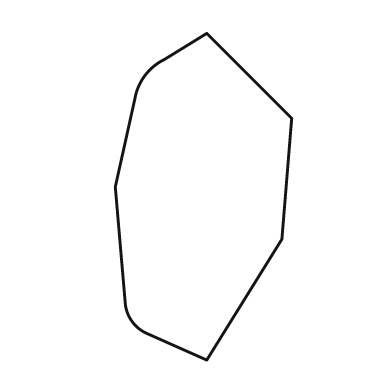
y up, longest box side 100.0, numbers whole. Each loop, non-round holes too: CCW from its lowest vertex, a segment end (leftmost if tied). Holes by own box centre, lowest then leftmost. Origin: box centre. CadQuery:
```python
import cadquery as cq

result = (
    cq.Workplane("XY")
    .moveTo(1.0, -50.0)
    .lineTo(24.0, -13.0)
    .lineTo(27.0, 24.0)
    .lineTo(1.0, 50.0)
    .lineTo(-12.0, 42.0)
    .threePointArc((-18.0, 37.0), (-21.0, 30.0))
    .lineTo(-27.0, 3.0)
    .lineTo(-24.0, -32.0)
    .threePointArc((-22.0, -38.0), (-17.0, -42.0))
    .close()
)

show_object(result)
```